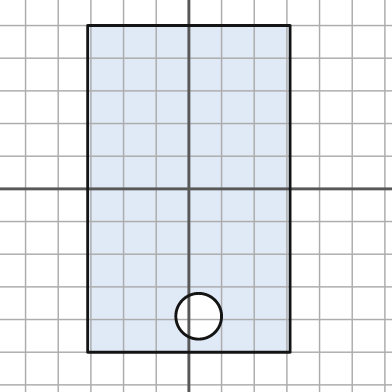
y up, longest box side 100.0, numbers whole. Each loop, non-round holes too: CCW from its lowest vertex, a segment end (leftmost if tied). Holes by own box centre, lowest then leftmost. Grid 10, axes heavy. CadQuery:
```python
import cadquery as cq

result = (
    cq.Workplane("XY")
    .moveTo(-31.0, -50.0)
    .lineTo(31.0, -50.0)
    .lineTo(31.0, 50.0)
    .lineTo(-31.0, 50.0)
    .close()
    .moveTo(3.0, -39.0)
    .circle(7.0)
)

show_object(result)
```